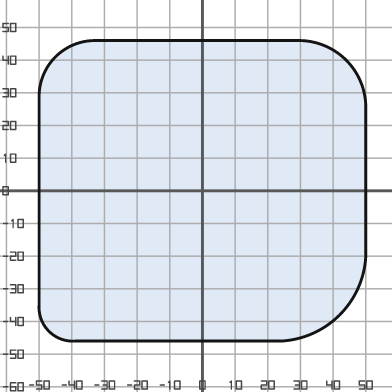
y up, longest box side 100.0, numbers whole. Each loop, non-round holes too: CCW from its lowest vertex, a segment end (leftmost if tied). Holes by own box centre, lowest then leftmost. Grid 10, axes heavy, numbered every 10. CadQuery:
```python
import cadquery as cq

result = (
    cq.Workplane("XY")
    .moveTo(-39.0, -46.0)
    .lineTo(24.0, -46.0)
    .threePointArc((42.0, -38.0), (50.0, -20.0))
    .lineTo(50.0, 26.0)
    .threePointArc((44.0, 40.0), (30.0, 46.0))
    .lineTo(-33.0, 46.0)
    .threePointArc((-45.0, 41.0), (-50.0, 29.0))
    .lineTo(-50.0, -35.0)
    .threePointArc((-47.0, -43.0), (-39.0, -46.0))
    .close()
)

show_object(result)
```